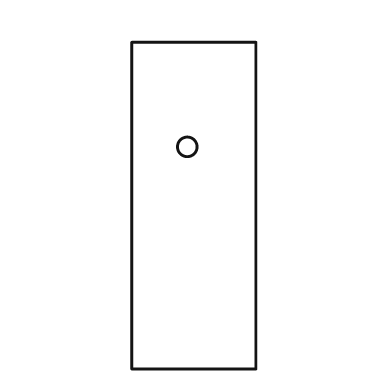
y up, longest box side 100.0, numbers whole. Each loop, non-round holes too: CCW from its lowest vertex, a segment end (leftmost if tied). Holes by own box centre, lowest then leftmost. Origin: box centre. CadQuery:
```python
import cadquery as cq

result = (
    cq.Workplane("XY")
    .moveTo(-19.0, -50.0)
    .lineTo(19.0, -50.0)
    .lineTo(19.0, 50.0)
    .lineTo(-19.0, 50.0)
    .close()
    .moveTo(-2.0, 18.0)
    .circle(3.0)
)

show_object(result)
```